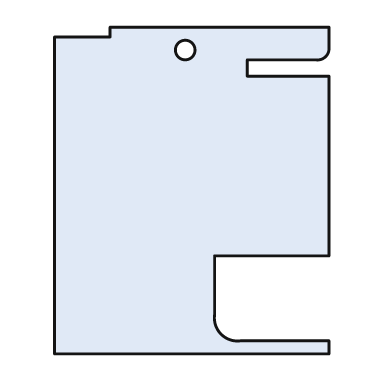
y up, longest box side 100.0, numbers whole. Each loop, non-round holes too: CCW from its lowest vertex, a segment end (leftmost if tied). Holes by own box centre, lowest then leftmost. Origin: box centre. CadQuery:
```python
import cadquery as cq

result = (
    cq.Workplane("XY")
    .moveTo(-42.0, -50.0)
    .lineTo(42.0, -50.0)
    .lineTo(42.0, -46.0)
    .lineTo(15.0, -46.0)
    .threePointArc((9.0, -44.0), (7.0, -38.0))
    .lineTo(7.0, -20.0)
    .lineTo(42.0, -20.0)
    .lineTo(42.0, 35.0)
    .lineTo(17.0, 35.0)
    .lineTo(17.0, 40.0)
    .lineTo(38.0, 40.0)
    .threePointArc((41.0, 41.0), (42.0, 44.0))
    .lineTo(42.0, 50.0)
    .lineTo(-25.0, 50.0)
    .lineTo(-25.0, 47.0)
    .lineTo(-42.0, 47.0)
    .close()
    .moveTo(-2.0, 43.0)
    .circle(3.0)
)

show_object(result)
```